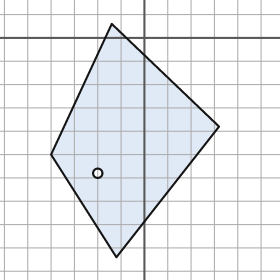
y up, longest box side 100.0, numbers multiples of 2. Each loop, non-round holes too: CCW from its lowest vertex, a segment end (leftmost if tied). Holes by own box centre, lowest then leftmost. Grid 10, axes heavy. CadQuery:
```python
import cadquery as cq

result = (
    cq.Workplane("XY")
    .moveTo(-12.0, -94.0)
    .lineTo(32.0, -38.0)
    .lineTo(-14.0, 6.0)
    .lineTo(-40.0, -50.0)
    .close()
    .moveTo(-20.0, -58.0)
    .circle(2.0)
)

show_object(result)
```